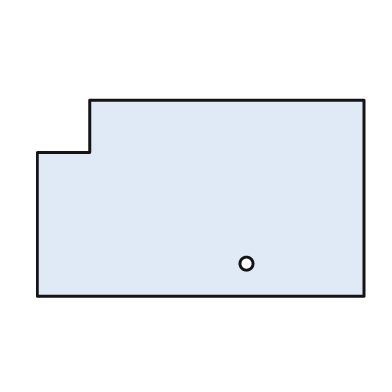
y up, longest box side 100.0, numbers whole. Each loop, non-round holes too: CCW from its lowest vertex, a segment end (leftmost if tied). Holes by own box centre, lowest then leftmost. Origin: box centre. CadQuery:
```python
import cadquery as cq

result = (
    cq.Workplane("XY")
    .moveTo(-50.0, -30.0)
    .lineTo(50.0, -30.0)
    .lineTo(50.0, 30.0)
    .lineTo(-34.0, 30.0)
    .lineTo(-34.0, 14.0)
    .lineTo(-50.0, 14.0)
    .close()
    .moveTo(14.0, -20.0)
    .circle(2.0)
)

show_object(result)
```